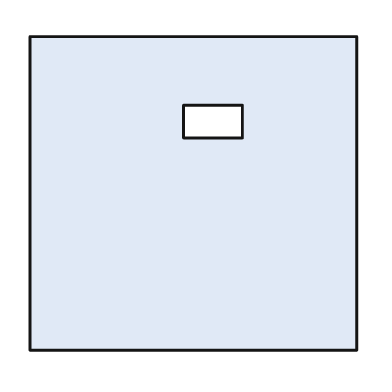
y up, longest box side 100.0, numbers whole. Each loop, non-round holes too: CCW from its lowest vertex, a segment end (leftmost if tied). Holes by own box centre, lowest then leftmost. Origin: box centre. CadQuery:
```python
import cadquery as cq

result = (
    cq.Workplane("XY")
    .moveTo(-50.0, -48.0)
    .lineTo(50.0, -48.0)
    .lineTo(50.0, 48.0)
    .lineTo(-50.0, 48.0)
    .close()
    .moveTo(-3.0, 17.0)
    .lineTo(15.0, 17.0)
    .lineTo(15.0, 27.0)
    .lineTo(-3.0, 27.0)
    .close()
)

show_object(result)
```